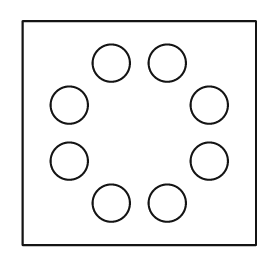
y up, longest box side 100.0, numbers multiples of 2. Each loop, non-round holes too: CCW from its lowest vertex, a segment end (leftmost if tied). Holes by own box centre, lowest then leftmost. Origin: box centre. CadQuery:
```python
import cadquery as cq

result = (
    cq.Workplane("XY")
    .moveTo(-50.0, -48.0)
    .lineTo(50.0, -48.0)
    .lineTo(50.0, 48.0)
    .lineTo(-50.0, 48.0)
    .close()
    .moveTo(-12.0, -30.0)
    .circle(8.0)
    .moveTo(12.0, -30.0)
    .circle(8.0)
    .moveTo(-30.0, -12.0)
    .circle(8.0)
    .moveTo(30.0, -12.0)
    .circle(8.0)
    .moveTo(-30.0, 12.0)
    .circle(8.0)
    .moveTo(30.0, 12.0)
    .circle(8.0)
    .moveTo(-12.0, 30.0)
    .circle(8.0)
    .moveTo(12.0, 30.0)
    .circle(8.0)
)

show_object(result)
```